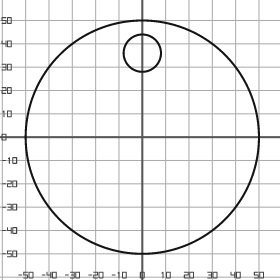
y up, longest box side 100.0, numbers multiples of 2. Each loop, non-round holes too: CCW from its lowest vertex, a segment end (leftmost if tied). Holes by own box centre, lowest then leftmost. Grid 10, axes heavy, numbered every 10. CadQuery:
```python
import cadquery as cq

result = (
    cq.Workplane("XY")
    .moveTo(0.0, 0.0)
    .circle(50.0)
    .moveTo(0.0, 36.0)
    .circle(8.0)
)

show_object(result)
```